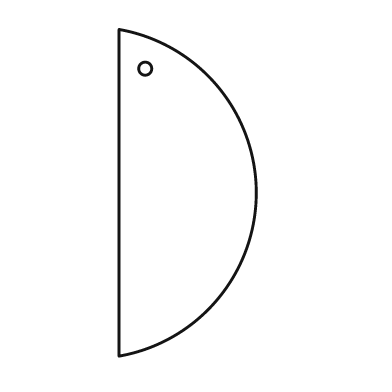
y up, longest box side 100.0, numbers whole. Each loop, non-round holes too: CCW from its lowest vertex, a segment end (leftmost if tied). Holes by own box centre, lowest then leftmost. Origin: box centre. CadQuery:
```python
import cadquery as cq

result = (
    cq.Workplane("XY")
    .moveTo(-21.0, -50.0)
    .threePointArc((21.0, 0.0), (-21.0, 50.0))
    .close()
    .moveTo(-13.0, 38.0)
    .circle(2.0)
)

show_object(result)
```